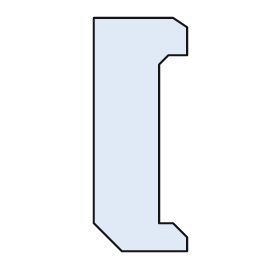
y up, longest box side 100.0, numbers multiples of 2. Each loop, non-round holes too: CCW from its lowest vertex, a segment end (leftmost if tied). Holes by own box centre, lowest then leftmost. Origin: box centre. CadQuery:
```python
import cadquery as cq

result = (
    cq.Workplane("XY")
    .moveTo(-8.0, -50.0)
    .lineTo(20.0, -50.0)
    .lineTo(20.0, -44.0)
    .lineTo(14.0, -38.0)
    .lineTo(8.0, -38.0)
    .lineTo(8.0, 30.0)
    .lineTo(12.0, 34.0)
    .lineTo(20.0, 34.0)
    .lineTo(20.0, 46.0)
    .lineTo(14.0, 50.0)
    .lineTo(-20.0, 50.0)
    .lineTo(-20.0, -38.0)
    .close()
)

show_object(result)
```